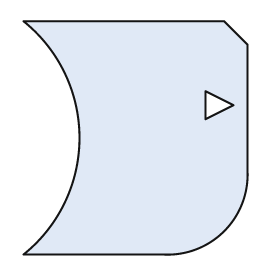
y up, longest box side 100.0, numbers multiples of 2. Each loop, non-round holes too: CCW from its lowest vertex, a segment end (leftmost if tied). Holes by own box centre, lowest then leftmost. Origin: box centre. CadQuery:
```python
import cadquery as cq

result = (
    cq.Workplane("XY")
    .moveTo(-48.0, -50.0)
    .lineTo(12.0, -50.0)
    .threePointArc((38.0, -40.0), (48.0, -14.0))
    .lineTo(48.0, 40.0)
    .lineTo(38.0, 50.0)
    .lineTo(-48.0, 50.0)
    .threePointArc((-24.0, 0.0), (-48.0, -50.0))
    .close()
    .moveTo(30.0, 8.0)
    .lineTo(42.0, 14.0)
    .lineTo(30.0, 20.0)
    .close()
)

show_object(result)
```